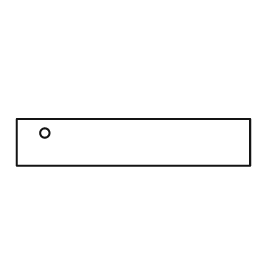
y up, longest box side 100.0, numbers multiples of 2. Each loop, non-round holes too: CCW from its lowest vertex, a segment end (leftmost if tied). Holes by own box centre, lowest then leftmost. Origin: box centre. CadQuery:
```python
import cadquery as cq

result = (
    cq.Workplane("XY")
    .moveTo(-50.0, -10.0)
    .lineTo(50.0, -10.0)
    .lineTo(50.0, 10.0)
    .lineTo(-50.0, 10.0)
    .close()
    .moveTo(-38.0, 4.0)
    .circle(2.0)
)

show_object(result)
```